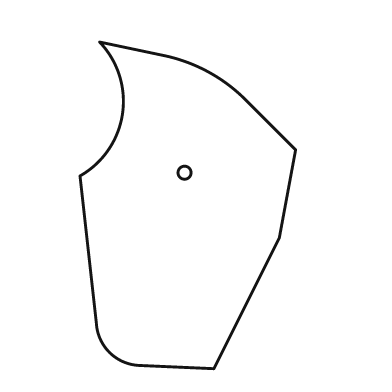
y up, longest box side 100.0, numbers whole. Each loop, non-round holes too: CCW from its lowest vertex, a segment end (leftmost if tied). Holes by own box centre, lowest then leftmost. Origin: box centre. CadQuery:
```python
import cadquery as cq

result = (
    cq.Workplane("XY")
    .moveTo(8.0, -50.0)
    .lineTo(28.0, -10.0)
    .lineTo(33.0, 17.0)
    .lineTo(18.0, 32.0)
    .threePointArc((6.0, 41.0), (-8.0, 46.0))
    .lineTo(-27.0, 50.0)
    .threePointArc((-20.0, 28.0), (-33.0, 9.0))
    .lineTo(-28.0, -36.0)
    .threePointArc((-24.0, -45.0), (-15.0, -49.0))
    .close()
    .moveTo(-1.0, 10.0)
    .circle(2.0)
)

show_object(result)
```